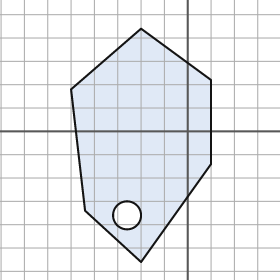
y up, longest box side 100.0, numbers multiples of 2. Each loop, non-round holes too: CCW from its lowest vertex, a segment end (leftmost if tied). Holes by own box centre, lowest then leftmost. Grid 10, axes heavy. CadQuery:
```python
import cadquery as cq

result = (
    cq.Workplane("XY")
    .moveTo(-20.0, -56.0)
    .lineTo(10.0, -14.0)
    .lineTo(10.0, 22.0)
    .lineTo(-20.0, 44.0)
    .lineTo(-50.0, 18.0)
    .lineTo(-44.0, -34.0)
    .close()
    .moveTo(-26.0, -36.0)
    .circle(6.0)
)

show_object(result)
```